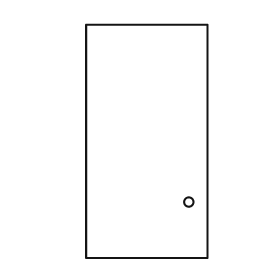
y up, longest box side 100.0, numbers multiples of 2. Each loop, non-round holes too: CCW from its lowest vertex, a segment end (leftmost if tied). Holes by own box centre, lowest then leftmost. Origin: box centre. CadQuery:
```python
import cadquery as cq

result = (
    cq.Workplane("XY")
    .moveTo(-26.0, -50.0)
    .lineTo(26.0, -50.0)
    .lineTo(26.0, 50.0)
    .lineTo(-26.0, 50.0)
    .close()
    .moveTo(18.0, -26.0)
    .circle(2.0)
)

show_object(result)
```